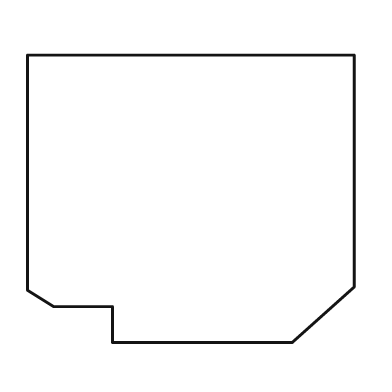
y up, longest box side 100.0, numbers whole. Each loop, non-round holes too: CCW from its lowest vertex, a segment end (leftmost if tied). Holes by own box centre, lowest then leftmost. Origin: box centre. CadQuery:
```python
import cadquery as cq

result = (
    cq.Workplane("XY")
    .moveTo(-24.0, -44.0)
    .lineTo(31.0, -44.0)
    .lineTo(50.0, -27.0)
    .lineTo(50.0, 44.0)
    .lineTo(-50.0, 44.0)
    .lineTo(-50.0, -28.0)
    .lineTo(-42.0, -33.0)
    .lineTo(-24.0, -33.0)
    .close()
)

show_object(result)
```